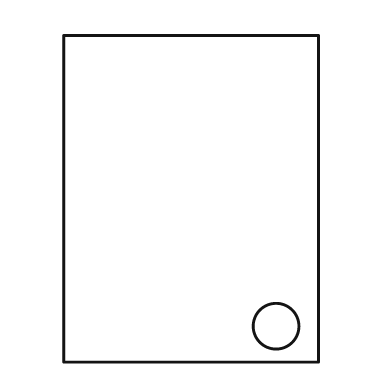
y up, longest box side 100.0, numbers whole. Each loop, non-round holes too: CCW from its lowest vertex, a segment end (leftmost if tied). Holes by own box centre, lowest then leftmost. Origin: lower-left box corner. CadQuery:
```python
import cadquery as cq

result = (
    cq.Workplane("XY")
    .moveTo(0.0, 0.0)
    .lineTo(78.0, 0.0)
    .lineTo(78.0, 100.0)
    .lineTo(0.0, 100.0)
    .close()
    .moveTo(65.0, 11.0)
    .circle(7.0)
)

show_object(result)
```